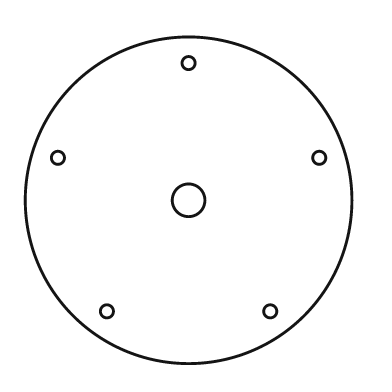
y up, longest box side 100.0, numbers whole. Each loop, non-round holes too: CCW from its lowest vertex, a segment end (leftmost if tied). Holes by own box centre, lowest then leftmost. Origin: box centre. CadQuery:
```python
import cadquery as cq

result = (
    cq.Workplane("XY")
    .moveTo(0.0, 0.0)
    .circle(50.0)
    .moveTo(-25.0, -34.0)
    .circle(2.0)
    .moveTo(25.0, -34.0)
    .circle(2.0)
    .moveTo(0.0, 0.0)
    .circle(5.0)
    .moveTo(-40.0, 13.0)
    .circle(2.0)
    .moveTo(40.0, 13.0)
    .circle(2.0)
    .moveTo(0.0, 42.0)
    .circle(2.0)
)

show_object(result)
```